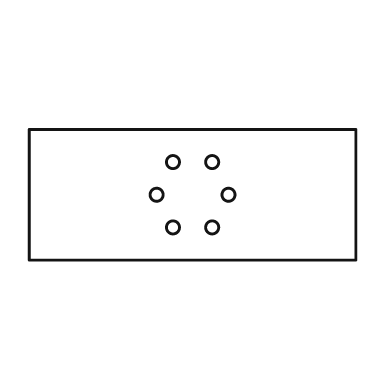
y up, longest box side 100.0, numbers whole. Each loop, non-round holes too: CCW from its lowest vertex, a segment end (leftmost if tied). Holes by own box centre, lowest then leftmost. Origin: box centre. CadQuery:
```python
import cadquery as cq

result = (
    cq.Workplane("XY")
    .moveTo(-50.0, -20.0)
    .lineTo(50.0, -20.0)
    .lineTo(50.0, 20.0)
    .lineTo(-50.0, 20.0)
    .close()
    .moveTo(-6.0, -10.0)
    .circle(2.0)
    .moveTo(6.0, -10.0)
    .circle(2.0)
    .moveTo(-11.0, 0.0)
    .circle(2.0)
    .moveTo(11.0, 0.0)
    .circle(2.0)
    .moveTo(-6.0, 10.0)
    .circle(2.0)
    .moveTo(6.0, 10.0)
    .circle(2.0)
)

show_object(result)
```